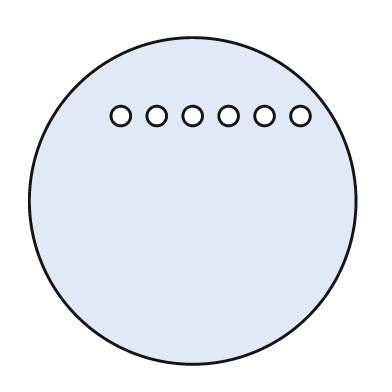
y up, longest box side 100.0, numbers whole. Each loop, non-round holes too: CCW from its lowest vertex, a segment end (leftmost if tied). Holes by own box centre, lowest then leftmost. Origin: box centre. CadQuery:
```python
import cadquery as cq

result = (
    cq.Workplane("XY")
    .moveTo(0.0, 0.0)
    .circle(50.0)
    .moveTo(-22.0, 26.0)
    .circle(3.0)
    .moveTo(-11.0, 26.0)
    .circle(3.0)
    .moveTo(0.0, 26.0)
    .circle(3.0)
    .moveTo(11.0, 26.0)
    .circle(3.0)
    .moveTo(22.0, 26.0)
    .circle(3.0)
    .moveTo(33.0, 26.0)
    .circle(3.0)
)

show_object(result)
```